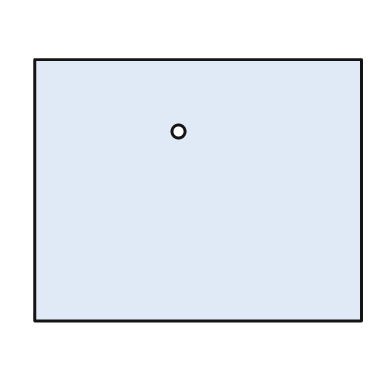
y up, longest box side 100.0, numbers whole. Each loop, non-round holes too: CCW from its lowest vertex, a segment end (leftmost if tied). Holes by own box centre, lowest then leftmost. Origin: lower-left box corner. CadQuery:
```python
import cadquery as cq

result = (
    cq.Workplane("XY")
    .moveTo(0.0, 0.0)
    .lineTo(100.0, 0.0)
    .lineTo(100.0, 80.0)
    .lineTo(0.0, 80.0)
    .close()
    .moveTo(44.0, 58.0)
    .circle(2.0)
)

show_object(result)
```